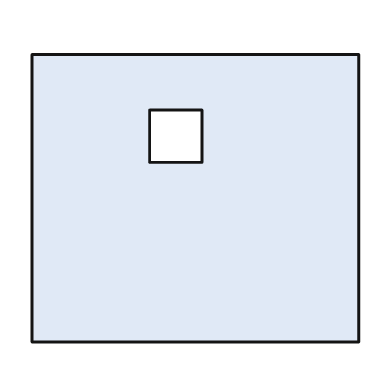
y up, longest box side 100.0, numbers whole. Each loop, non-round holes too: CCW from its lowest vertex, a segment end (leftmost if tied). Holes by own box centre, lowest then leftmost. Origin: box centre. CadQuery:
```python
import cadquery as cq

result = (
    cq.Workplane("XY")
    .moveTo(-50.0, -44.0)
    .lineTo(50.0, -44.0)
    .lineTo(50.0, 44.0)
    .lineTo(-50.0, 44.0)
    .close()
    .moveTo(-14.0, 11.0)
    .lineTo(2.0, 11.0)
    .lineTo(2.0, 27.0)
    .lineTo(-14.0, 27.0)
    .close()
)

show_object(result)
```